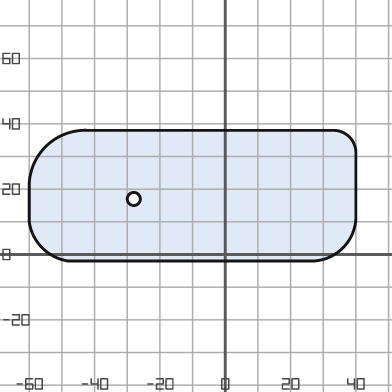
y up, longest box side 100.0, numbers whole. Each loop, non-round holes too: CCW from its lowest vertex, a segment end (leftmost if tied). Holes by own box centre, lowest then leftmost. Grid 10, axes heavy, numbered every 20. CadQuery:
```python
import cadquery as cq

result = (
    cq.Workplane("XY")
    .moveTo(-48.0, -2.0)
    .lineTo(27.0, -2.0)
    .threePointArc((36.0, 2.0), (40.0, 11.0))
    .lineTo(40.0, 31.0)
    .threePointArc((38.0, 36.0), (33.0, 38.0))
    .lineTo(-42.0, 38.0)
    .threePointArc((-55.0, 33.0), (-60.0, 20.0))
    .lineTo(-60.0, 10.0)
    .threePointArc((-56.0, 2.0), (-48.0, -2.0))
    .close()
    .moveTo(-28.0, 17.0)
    .circle(2.0)
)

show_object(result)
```